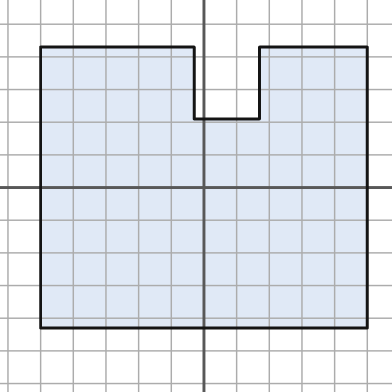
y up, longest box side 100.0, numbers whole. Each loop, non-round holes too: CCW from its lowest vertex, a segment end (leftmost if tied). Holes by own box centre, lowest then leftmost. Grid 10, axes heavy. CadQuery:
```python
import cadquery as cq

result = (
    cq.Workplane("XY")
    .moveTo(-50.0, -43.0)
    .lineTo(50.0, -43.0)
    .lineTo(50.0, 43.0)
    .lineTo(17.0, 43.0)
    .lineTo(17.0, 21.0)
    .lineTo(-3.0, 21.0)
    .lineTo(-3.0, 43.0)
    .lineTo(-50.0, 43.0)
    .close()
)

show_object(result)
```